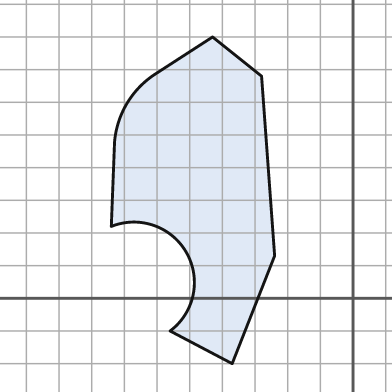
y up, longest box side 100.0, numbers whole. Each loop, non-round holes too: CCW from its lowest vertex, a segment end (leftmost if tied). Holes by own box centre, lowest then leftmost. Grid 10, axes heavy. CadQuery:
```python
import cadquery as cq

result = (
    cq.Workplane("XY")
    .moveTo(-37.0, -20.0)
    .lineTo(-24.0, 13.0)
    .lineTo(-28.0, 68.0)
    .lineTo(-43.0, 80.0)
    .lineTo(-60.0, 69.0)
    .threePointArc((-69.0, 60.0), (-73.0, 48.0))
    .lineTo(-74.0, 22.0)
    .threePointArc((-51.0, 14.0), (-56.0, -10.0))
    .close()
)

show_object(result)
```